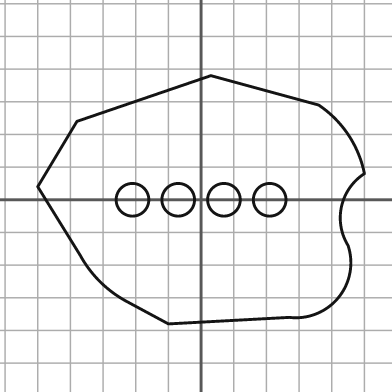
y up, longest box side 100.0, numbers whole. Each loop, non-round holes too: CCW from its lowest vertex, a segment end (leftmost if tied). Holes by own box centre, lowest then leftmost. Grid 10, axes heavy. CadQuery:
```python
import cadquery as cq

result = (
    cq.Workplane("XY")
    .moveTo(-10.0, -38.0)
    .lineTo(27.0, -36.0)
    .threePointArc((42.0, -30.0), (45.0, -14.0))
    .threePointArc((43.0, -2.0), (50.0, 8.0))
    .threePointArc((45.0, 20.0), (36.0, 29.0))
    .lineTo(3.0, 38.0)
    .lineTo(-38.0, 24.0)
    .lineTo(-50.0, 4.0)
    .lineTo(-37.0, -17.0)
    .threePointArc((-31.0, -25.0), (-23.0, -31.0))
    .close()
    .moveTo(-21.0, 0.0)
    .circle(5.0)
    .moveTo(-7.0, 0.0)
    .circle(5.0)
    .moveTo(7.0, 0.0)
    .circle(5.0)
    .moveTo(21.0, 0.0)
    .circle(5.0)
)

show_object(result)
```